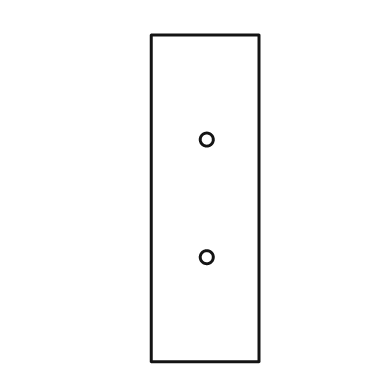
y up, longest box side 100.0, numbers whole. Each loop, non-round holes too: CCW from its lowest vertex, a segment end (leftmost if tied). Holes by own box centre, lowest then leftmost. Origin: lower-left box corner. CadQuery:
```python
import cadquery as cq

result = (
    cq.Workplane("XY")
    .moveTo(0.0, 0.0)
    .lineTo(33.0, 0.0)
    .lineTo(33.0, 100.0)
    .lineTo(0.0, 100.0)
    .close()
    .moveTo(17.0, 32.0)
    .circle(2.0)
    .moveTo(17.0, 68.0)
    .circle(2.0)
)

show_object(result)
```